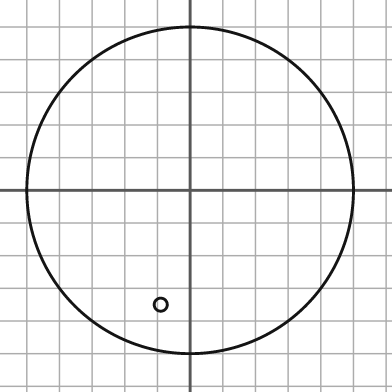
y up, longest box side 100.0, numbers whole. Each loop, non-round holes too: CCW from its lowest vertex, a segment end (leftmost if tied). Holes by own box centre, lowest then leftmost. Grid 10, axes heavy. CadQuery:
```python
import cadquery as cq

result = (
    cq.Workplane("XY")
    .moveTo(0.0, 0.0)
    .circle(50.0)
    .moveTo(-9.0, -35.0)
    .circle(2.0)
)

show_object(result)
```